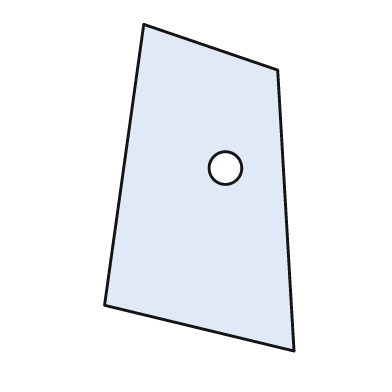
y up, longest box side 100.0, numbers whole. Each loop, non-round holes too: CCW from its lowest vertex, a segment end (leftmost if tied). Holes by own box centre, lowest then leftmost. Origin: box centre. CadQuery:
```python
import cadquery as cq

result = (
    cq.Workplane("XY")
    .moveTo(29.0, -50.0)
    .lineTo(24.0, 36.0)
    .lineTo(-17.0, 50.0)
    .lineTo(-29.0, -36.0)
    .close()
    .moveTo(8.0, 6.0)
    .circle(5.0)
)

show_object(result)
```